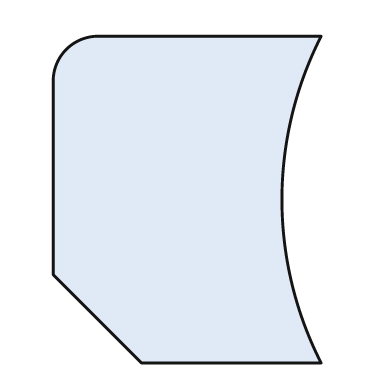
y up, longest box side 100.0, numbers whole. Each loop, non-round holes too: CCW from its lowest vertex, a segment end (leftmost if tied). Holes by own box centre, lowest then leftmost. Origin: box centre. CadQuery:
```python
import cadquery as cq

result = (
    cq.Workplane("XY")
    .moveTo(-14.0, -50.0)
    .lineTo(41.0, -50.0)
    .threePointArc((29.0, 0.0), (41.0, 50.0))
    .lineTo(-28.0, 50.0)
    .threePointArc((-37.0, 46.0), (-41.0, 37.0))
    .lineTo(-41.0, -23.0)
    .close()
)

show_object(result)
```